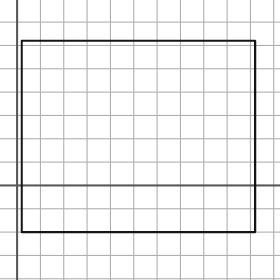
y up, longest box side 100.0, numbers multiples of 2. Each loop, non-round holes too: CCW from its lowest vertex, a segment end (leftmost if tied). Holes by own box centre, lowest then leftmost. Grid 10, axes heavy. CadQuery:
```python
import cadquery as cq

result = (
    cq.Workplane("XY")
    .moveTo(2.0, -20.0)
    .lineTo(102.0, -20.0)
    .lineTo(102.0, 62.0)
    .lineTo(2.0, 62.0)
    .close()
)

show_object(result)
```